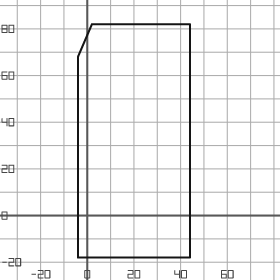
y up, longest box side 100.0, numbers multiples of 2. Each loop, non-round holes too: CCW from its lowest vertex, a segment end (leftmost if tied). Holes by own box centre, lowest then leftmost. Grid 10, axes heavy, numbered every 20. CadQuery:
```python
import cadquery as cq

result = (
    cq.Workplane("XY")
    .moveTo(-4.0, -18.0)
    .lineTo(44.0, -18.0)
    .lineTo(44.0, 82.0)
    .lineTo(2.0, 82.0)
    .lineTo(-4.0, 68.0)
    .close()
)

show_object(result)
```